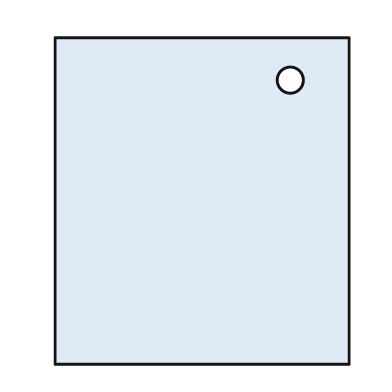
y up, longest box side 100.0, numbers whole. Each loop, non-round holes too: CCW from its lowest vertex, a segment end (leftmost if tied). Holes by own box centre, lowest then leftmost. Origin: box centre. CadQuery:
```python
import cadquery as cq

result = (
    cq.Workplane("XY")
    .moveTo(-45.0, -50.0)
    .lineTo(45.0, -50.0)
    .lineTo(45.0, 50.0)
    .lineTo(-45.0, 50.0)
    .close()
    .moveTo(27.0, 37.0)
    .circle(4.0)
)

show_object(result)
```